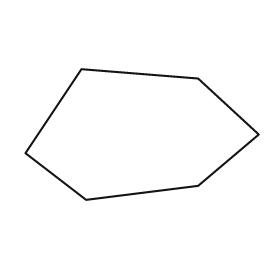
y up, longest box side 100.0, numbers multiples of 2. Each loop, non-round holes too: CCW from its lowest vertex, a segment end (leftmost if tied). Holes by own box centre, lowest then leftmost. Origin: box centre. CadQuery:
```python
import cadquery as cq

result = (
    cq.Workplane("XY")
    .moveTo(-24.0, -28.0)
    .lineTo(24.0, -22.0)
    .lineTo(50.0, 0.0)
    .lineTo(24.0, 24.0)
    .lineTo(-26.0, 28.0)
    .lineTo(-50.0, -8.0)
    .close()
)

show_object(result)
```